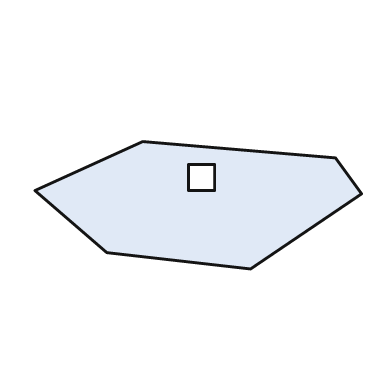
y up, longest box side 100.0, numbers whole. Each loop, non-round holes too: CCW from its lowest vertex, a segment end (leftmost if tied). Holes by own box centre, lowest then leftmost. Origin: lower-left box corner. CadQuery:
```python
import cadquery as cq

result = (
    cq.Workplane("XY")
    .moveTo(66.0, 0.0)
    .lineTo(100.0, 23.0)
    .lineTo(92.0, 34.0)
    .lineTo(33.0, 39.0)
    .lineTo(0.0, 24.0)
    .lineTo(22.0, 5.0)
    .close()
    .moveTo(47.0, 24.0)
    .lineTo(55.0, 24.0)
    .lineTo(55.0, 32.0)
    .lineTo(47.0, 32.0)
    .close()
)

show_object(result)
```